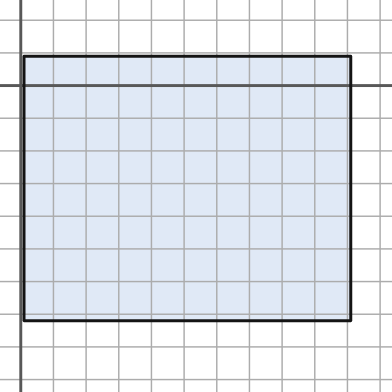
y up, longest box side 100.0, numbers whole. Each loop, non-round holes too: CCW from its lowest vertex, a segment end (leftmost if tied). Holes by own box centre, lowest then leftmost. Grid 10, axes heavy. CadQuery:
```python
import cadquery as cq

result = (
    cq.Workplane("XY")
    .moveTo(1.0, -72.0)
    .lineTo(101.0, -72.0)
    .lineTo(101.0, 9.0)
    .lineTo(1.0, 9.0)
    .close()
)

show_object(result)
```